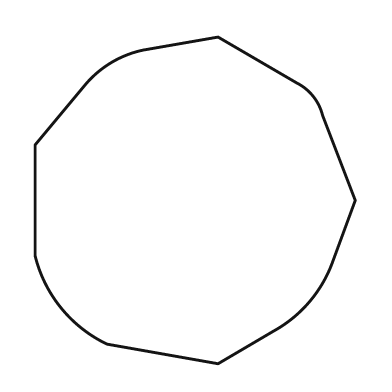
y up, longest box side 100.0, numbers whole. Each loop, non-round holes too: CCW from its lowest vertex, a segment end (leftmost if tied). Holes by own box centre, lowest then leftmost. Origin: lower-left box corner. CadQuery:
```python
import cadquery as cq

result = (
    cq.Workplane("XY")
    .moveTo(56.0, 0.0)
    .lineTo(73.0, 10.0)
    .threePointArc((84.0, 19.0), (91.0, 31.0))
    .lineTo(98.0, 50.0)
    .lineTo(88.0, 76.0)
    .threePointArc((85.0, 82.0), (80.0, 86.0))
    .lineTo(56.0, 100.0)
    .lineTo(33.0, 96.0)
    .threePointArc((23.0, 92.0), (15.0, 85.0))
    .lineTo(0.0, 67.0)
    .lineTo(0.0, 33.0)
    .threePointArc((8.0, 17.0), (22.0, 6.0))
    .close()
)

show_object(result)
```